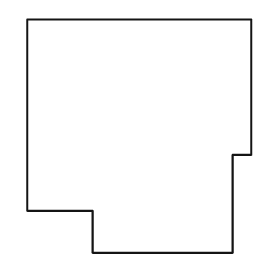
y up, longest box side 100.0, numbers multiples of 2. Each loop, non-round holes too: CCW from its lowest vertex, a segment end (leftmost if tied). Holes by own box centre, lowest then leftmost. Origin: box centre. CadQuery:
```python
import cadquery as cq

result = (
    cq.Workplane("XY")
    .moveTo(-20.0, -50.0)
    .lineTo(40.0, -50.0)
    .lineTo(40.0, -8.0)
    .lineTo(48.0, -8.0)
    .lineTo(48.0, 50.0)
    .lineTo(-48.0, 50.0)
    .lineTo(-48.0, -32.0)
    .lineTo(-20.0, -32.0)
    .close()
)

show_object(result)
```